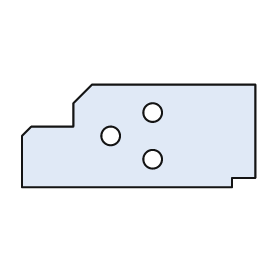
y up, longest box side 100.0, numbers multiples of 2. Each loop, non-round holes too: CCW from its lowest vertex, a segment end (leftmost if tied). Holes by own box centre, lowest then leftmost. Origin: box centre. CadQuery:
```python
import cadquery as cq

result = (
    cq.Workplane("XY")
    .moveTo(-50.0, -22.0)
    .lineTo(40.0, -22.0)
    .lineTo(40.0, -18.0)
    .lineTo(50.0, -18.0)
    .lineTo(50.0, 22.0)
    .lineTo(-20.0, 22.0)
    .lineTo(-28.0, 14.0)
    .lineTo(-28.0, 4.0)
    .lineTo(-46.0, 4.0)
    .lineTo(-50.0, 0.0)
    .close()
    .moveTo(6.0, -10.0)
    .circle(4.0)
    .moveTo(-12.0, 0.0)
    .circle(4.0)
    .moveTo(6.0, 10.0)
    .circle(4.0)
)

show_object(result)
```